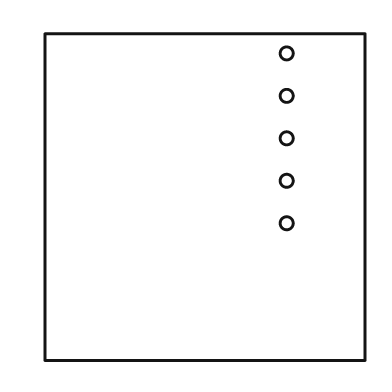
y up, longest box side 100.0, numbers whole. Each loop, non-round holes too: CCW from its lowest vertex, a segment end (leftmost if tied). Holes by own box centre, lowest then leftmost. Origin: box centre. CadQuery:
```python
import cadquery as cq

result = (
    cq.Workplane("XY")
    .moveTo(-49.0, -50.0)
    .lineTo(49.0, -50.0)
    .lineTo(49.0, 50.0)
    .lineTo(-49.0, 50.0)
    .close()
    .moveTo(25.0, -8.0)
    .circle(2.0)
    .moveTo(25.0, 5.0)
    .circle(2.0)
    .moveTo(25.0, 18.0)
    .circle(2.0)
    .moveTo(25.0, 31.0)
    .circle(2.0)
    .moveTo(25.0, 44.0)
    .circle(2.0)
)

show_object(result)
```